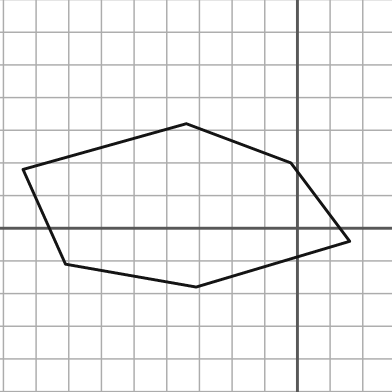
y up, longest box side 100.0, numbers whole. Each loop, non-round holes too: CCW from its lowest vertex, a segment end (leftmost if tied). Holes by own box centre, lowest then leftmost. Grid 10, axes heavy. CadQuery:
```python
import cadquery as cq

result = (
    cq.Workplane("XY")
    .moveTo(-31.0, -18.0)
    .lineTo(16.0, -4.0)
    .lineTo(-2.0, 20.0)
    .lineTo(-34.0, 32.0)
    .lineTo(-84.0, 18.0)
    .lineTo(-71.0, -11.0)
    .close()
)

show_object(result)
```